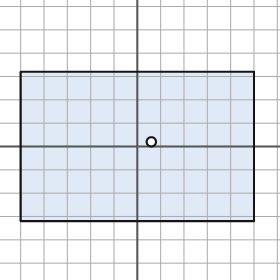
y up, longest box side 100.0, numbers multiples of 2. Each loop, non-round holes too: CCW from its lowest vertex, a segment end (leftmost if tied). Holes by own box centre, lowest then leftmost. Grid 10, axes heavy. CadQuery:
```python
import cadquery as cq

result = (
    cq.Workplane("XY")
    .moveTo(-50.0, -32.0)
    .lineTo(50.0, -32.0)
    .lineTo(50.0, 32.0)
    .lineTo(-50.0, 32.0)
    .close()
    .moveTo(6.0, 2.0)
    .circle(2.0)
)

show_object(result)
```